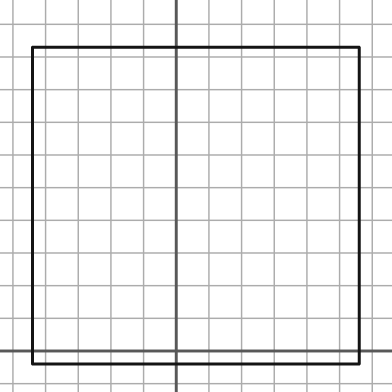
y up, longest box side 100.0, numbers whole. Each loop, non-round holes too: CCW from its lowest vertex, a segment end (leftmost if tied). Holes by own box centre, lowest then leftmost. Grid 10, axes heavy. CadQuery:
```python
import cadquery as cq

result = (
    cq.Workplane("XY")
    .moveTo(-44.0, -4.0)
    .lineTo(56.0, -4.0)
    .lineTo(56.0, 93.0)
    .lineTo(-44.0, 93.0)
    .close()
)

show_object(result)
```